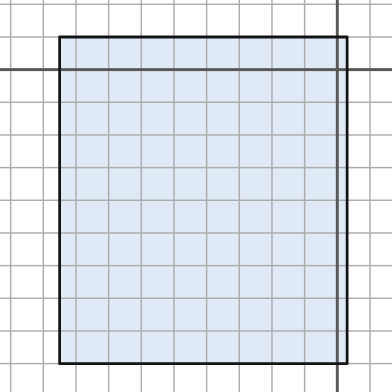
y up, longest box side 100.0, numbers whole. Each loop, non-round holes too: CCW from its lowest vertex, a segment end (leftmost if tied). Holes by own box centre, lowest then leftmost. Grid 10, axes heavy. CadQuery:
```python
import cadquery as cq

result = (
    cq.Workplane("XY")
    .moveTo(-85.0, -90.0)
    .lineTo(3.0, -90.0)
    .lineTo(3.0, 10.0)
    .lineTo(-85.0, 10.0)
    .close()
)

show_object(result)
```